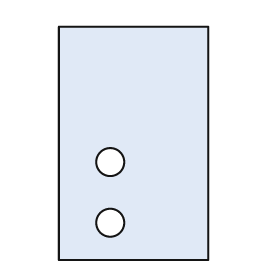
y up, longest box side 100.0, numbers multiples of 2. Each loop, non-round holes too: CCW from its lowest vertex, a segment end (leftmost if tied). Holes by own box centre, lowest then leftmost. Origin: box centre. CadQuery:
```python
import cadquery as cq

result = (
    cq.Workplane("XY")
    .moveTo(-32.0, -50.0)
    .lineTo(32.0, -50.0)
    .lineTo(32.0, 50.0)
    .lineTo(-32.0, 50.0)
    .close()
    .moveTo(-10.0, -34.0)
    .circle(6.0)
    .moveTo(-10.0, -8.0)
    .circle(6.0)
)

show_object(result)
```